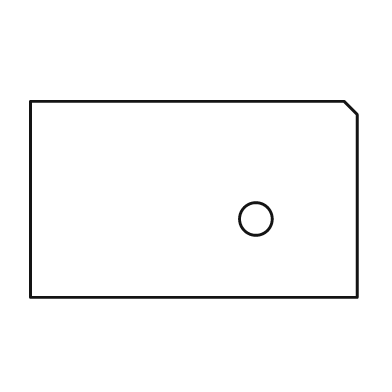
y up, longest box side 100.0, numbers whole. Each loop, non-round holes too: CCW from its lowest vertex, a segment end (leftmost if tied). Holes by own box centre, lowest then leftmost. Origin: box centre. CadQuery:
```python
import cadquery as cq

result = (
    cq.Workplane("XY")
    .moveTo(-50.0, -30.0)
    .lineTo(50.0, -30.0)
    .lineTo(50.0, 26.0)
    .lineTo(46.0, 30.0)
    .lineTo(-50.0, 30.0)
    .close()
    .moveTo(19.0, -6.0)
    .circle(5.0)
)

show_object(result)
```